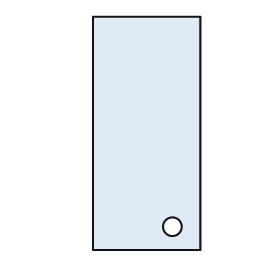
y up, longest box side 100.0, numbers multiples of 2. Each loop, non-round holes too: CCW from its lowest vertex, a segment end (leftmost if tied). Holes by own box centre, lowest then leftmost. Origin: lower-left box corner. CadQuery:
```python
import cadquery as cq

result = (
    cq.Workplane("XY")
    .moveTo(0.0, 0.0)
    .lineTo(46.0, 0.0)
    .lineTo(46.0, 100.0)
    .lineTo(0.0, 100.0)
    .close()
    .moveTo(34.0, 10.0)
    .circle(4.0)
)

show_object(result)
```